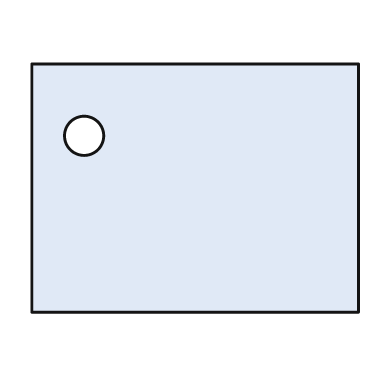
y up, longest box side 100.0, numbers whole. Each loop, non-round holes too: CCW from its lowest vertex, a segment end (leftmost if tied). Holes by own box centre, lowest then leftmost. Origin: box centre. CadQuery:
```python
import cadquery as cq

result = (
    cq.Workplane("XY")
    .moveTo(-50.0, -38.0)
    .lineTo(50.0, -38.0)
    .lineTo(50.0, 38.0)
    .lineTo(-50.0, 38.0)
    .close()
    .moveTo(-34.0, 16.0)
    .circle(6.0)
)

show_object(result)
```